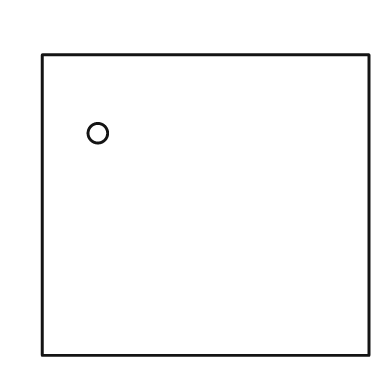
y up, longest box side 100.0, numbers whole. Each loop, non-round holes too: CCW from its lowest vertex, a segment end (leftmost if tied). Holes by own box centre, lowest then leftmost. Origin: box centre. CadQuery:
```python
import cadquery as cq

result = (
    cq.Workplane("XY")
    .moveTo(-50.0, -46.0)
    .lineTo(50.0, -46.0)
    .lineTo(50.0, 46.0)
    .lineTo(-50.0, 46.0)
    .close()
    .moveTo(-33.0, 22.0)
    .circle(3.0)
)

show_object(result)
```